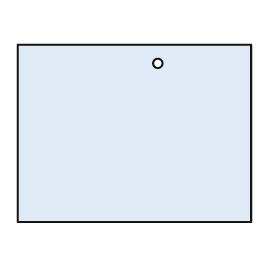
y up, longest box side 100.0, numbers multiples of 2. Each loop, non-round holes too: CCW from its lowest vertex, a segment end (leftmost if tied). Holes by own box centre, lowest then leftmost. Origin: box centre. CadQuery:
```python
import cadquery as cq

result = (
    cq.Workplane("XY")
    .moveTo(-50.0, -38.0)
    .lineTo(50.0, -38.0)
    .lineTo(50.0, 38.0)
    .lineTo(-50.0, 38.0)
    .close()
    .moveTo(10.0, 30.0)
    .circle(2.0)
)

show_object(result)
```